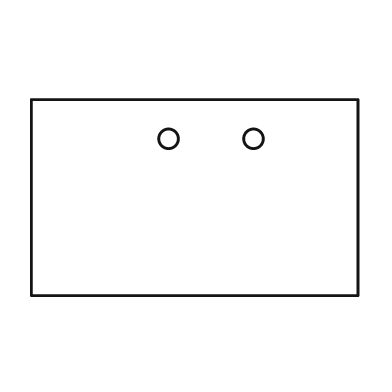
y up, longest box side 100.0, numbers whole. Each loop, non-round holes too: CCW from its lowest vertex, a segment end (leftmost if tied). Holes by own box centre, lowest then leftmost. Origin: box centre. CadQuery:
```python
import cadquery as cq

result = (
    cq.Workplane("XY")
    .moveTo(-50.0, -30.0)
    .lineTo(50.0, -30.0)
    .lineTo(50.0, 30.0)
    .lineTo(-50.0, 30.0)
    .close()
    .moveTo(-8.0, 18.0)
    .circle(3.0)
    .moveTo(18.0, 18.0)
    .circle(3.0)
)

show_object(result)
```